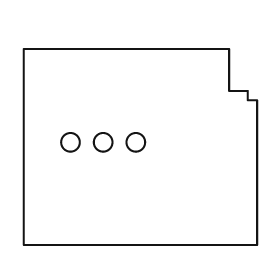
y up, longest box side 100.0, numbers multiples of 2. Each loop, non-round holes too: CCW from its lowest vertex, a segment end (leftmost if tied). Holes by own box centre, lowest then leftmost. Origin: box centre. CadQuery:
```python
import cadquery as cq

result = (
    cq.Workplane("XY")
    .moveTo(-50.0, -42.0)
    .lineTo(50.0, -42.0)
    .lineTo(50.0, 20.0)
    .lineTo(46.0, 20.0)
    .lineTo(46.0, 24.0)
    .lineTo(38.0, 24.0)
    .lineTo(38.0, 42.0)
    .lineTo(-50.0, 42.0)
    .close()
    .moveTo(-30.0, 2.0)
    .circle(4.0)
    .moveTo(-16.0, 2.0)
    .circle(4.0)
    .moveTo(-2.0, 2.0)
    .circle(4.0)
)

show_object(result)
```